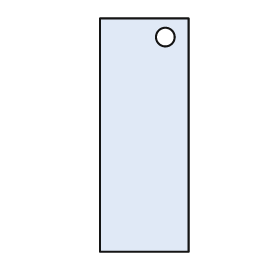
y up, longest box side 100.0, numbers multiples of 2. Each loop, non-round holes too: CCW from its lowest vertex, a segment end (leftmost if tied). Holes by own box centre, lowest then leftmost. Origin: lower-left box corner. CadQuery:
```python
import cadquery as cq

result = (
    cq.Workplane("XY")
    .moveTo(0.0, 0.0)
    .lineTo(38.0, 0.0)
    .lineTo(38.0, 100.0)
    .lineTo(0.0, 100.0)
    .close()
    .moveTo(28.0, 92.0)
    .circle(4.0)
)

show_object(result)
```